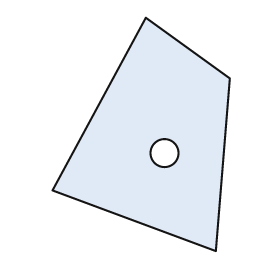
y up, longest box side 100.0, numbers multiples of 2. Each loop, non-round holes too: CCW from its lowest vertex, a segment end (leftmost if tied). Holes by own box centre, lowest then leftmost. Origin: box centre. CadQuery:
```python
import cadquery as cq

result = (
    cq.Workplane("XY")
    .moveTo(32.0, -50.0)
    .lineTo(38.0, 24.0)
    .lineTo(2.0, 50.0)
    .lineTo(-38.0, -24.0)
    .close()
    .moveTo(10.0, -8.0)
    .circle(6.0)
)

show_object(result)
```